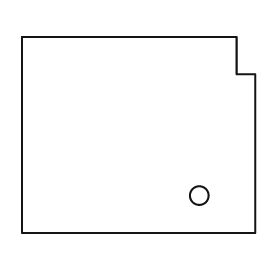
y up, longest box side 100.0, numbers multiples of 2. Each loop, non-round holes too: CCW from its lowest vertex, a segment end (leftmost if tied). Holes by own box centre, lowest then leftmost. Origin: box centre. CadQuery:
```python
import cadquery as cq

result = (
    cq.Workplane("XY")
    .moveTo(-50.0, -42.0)
    .lineTo(50.0, -42.0)
    .lineTo(50.0, 26.0)
    .lineTo(42.0, 26.0)
    .lineTo(42.0, 42.0)
    .lineTo(-50.0, 42.0)
    .close()
    .moveTo(26.0, -26.0)
    .circle(4.0)
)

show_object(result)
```